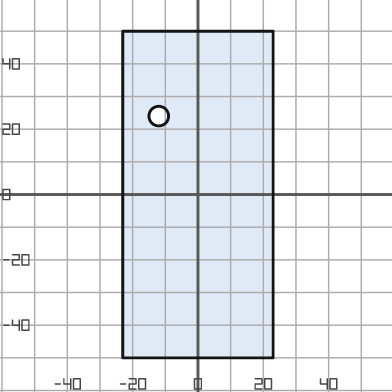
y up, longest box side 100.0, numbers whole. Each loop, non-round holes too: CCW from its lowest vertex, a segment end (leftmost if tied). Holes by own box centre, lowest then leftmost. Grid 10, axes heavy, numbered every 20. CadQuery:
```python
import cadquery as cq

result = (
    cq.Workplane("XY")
    .moveTo(-23.0, -50.0)
    .lineTo(23.0, -50.0)
    .lineTo(23.0, 50.0)
    .lineTo(-23.0, 50.0)
    .close()
    .moveTo(-12.0, 24.0)
    .circle(3.0)
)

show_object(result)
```